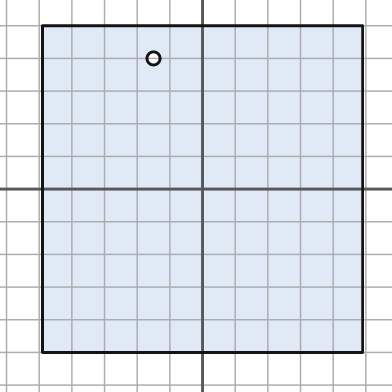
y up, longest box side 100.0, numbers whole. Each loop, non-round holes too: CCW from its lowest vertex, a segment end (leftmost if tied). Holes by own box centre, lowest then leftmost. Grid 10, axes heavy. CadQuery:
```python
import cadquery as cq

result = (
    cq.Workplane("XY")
    .moveTo(-49.0, -50.0)
    .lineTo(49.0, -50.0)
    .lineTo(49.0, 50.0)
    .lineTo(-49.0, 50.0)
    .close()
    .moveTo(-15.0, 40.0)
    .circle(2.0)
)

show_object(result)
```